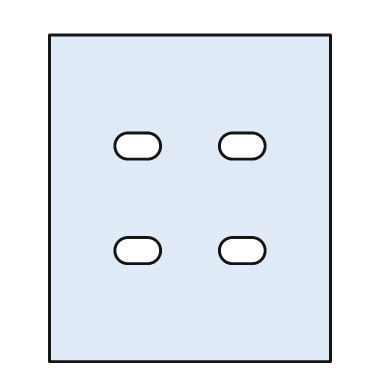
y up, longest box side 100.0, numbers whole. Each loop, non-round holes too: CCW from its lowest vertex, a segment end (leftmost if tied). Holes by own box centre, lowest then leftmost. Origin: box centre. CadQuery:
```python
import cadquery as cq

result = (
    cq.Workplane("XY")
    .moveTo(-43.0, -50.0)
    .lineTo(43.0, -50.0)
    .lineTo(43.0, 50.0)
    .lineTo(-43.0, 50.0)
    .close()
    .moveTo(-19.0, -20.0)
    .lineTo(-13.0, -20.0)
    .threePointArc((-9.0, -16.0), (-13.0, -12.0))
    .lineTo(-19.0, -12.0)
    .threePointArc((-23.0, -16.0), (-19.0, -20.0))
    .close()
    .moveTo(13.0, -20.0)
    .lineTo(19.0, -20.0)
    .threePointArc((23.0, -16.0), (19.0, -12.0))
    .lineTo(13.0, -12.0)
    .threePointArc((9.0, -16.0), (13.0, -20.0))
    .close()
    .moveTo(-19.0, 12.0)
    .lineTo(-13.0, 12.0)
    .threePointArc((-9.0, 16.0), (-13.0, 20.0))
    .lineTo(-19.0, 20.0)
    .threePointArc((-23.0, 16.0), (-19.0, 12.0))
    .close()
    .moveTo(13.0, 12.0)
    .lineTo(19.0, 12.0)
    .threePointArc((23.0, 16.0), (19.0, 20.0))
    .lineTo(13.0, 20.0)
    .threePointArc((9.0, 16.0), (13.0, 12.0))
    .close()
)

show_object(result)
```